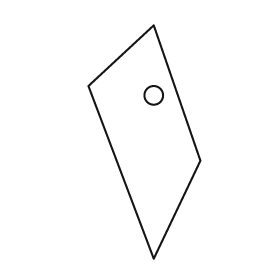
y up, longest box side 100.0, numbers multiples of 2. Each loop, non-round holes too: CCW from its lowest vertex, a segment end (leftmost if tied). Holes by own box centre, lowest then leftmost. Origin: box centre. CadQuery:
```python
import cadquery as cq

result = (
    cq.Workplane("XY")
    .moveTo(4.0, -50.0)
    .lineTo(24.0, -8.0)
    .lineTo(4.0, 50.0)
    .lineTo(-24.0, 24.0)
    .close()
    .moveTo(4.0, 20.0)
    .circle(4.0)
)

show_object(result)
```